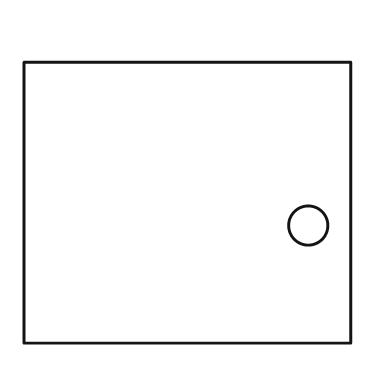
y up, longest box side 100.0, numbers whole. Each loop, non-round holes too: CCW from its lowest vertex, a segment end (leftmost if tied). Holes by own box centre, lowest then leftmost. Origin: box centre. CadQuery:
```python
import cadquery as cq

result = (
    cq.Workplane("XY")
    .moveTo(-50.0, -43.0)
    .lineTo(50.0, -43.0)
    .lineTo(50.0, 43.0)
    .lineTo(-50.0, 43.0)
    .close()
    .moveTo(37.0, -7.0)
    .circle(6.0)
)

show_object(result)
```